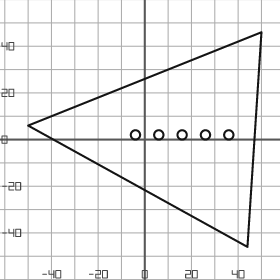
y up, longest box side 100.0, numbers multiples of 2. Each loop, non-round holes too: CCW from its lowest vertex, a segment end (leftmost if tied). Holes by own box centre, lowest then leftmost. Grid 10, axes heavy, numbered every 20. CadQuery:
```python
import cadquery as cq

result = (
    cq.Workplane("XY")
    .moveTo(44.0, -46.0)
    .lineTo(50.0, 46.0)
    .lineTo(-50.0, 6.0)
    .close()
    .moveTo(-4.0, 2.0)
    .circle(2.0)
    .moveTo(6.0, 2.0)
    .circle(2.0)
    .moveTo(16.0, 2.0)
    .circle(2.0)
    .moveTo(26.0, 2.0)
    .circle(2.0)
    .moveTo(36.0, 2.0)
    .circle(2.0)
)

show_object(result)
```